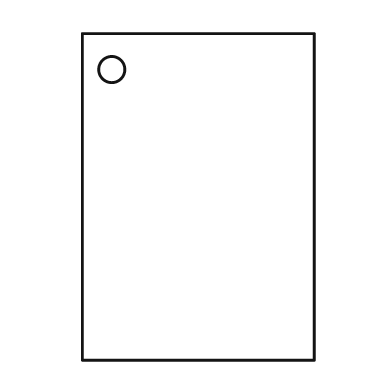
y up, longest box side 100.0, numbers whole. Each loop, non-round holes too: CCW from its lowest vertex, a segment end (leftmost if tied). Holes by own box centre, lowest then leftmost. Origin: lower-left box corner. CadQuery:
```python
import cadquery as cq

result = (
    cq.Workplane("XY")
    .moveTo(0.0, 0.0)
    .lineTo(71.0, 0.0)
    .lineTo(71.0, 100.0)
    .lineTo(0.0, 100.0)
    .close()
    .moveTo(9.0, 89.0)
    .circle(4.0)
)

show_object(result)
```